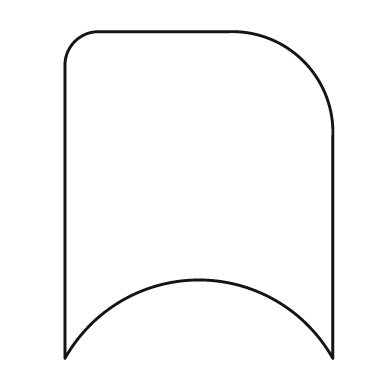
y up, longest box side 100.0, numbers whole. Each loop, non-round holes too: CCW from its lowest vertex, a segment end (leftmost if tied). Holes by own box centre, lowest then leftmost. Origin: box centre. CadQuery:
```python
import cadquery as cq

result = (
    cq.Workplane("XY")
    .moveTo(-41.0, -50.0)
    .threePointArc((0.0, -26.0), (41.0, -50.0))
    .lineTo(41.0, 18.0)
    .threePointArc((32.0, 41.0), (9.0, 50.0))
    .lineTo(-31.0, 50.0)
    .threePointArc((-38.0, 47.0), (-41.0, 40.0))
    .close()
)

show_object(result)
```